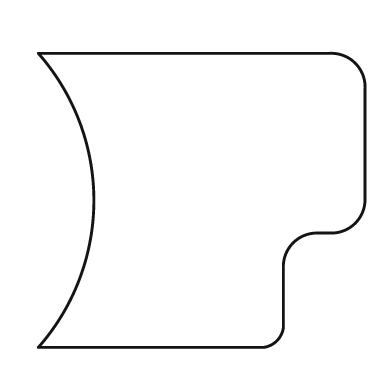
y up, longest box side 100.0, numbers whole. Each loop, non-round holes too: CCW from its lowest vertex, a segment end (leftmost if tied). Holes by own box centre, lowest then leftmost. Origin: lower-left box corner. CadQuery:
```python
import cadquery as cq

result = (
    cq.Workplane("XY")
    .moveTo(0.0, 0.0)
    .lineTo(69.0, 0.0)
    .threePointArc((73.0, 2.0), (75.0, 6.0))
    .lineTo(75.0, 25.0)
    .threePointArc((78.0, 32.0), (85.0, 35.0))
    .lineTo(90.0, 35.0)
    .threePointArc((97.0, 38.0), (100.0, 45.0))
    .lineTo(100.0, 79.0)
    .threePointArc((97.0, 87.0), (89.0, 90.0))
    .lineTo(0.0, 90.0)
    .threePointArc((17.0, 45.0), (0.0, 0.0))
    .close()
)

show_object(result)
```